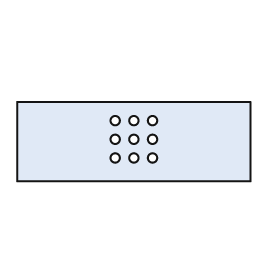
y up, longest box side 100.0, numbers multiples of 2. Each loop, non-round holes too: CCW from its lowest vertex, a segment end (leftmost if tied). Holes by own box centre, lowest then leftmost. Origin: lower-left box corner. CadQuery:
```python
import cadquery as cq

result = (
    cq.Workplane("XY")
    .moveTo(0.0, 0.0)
    .lineTo(100.0, 0.0)
    .lineTo(100.0, 34.0)
    .lineTo(0.0, 34.0)
    .close()
    .moveTo(42.0, 10.0)
    .circle(2.0)
    .moveTo(50.0, 10.0)
    .circle(2.0)
    .moveTo(58.0, 10.0)
    .circle(2.0)
    .moveTo(42.0, 18.0)
    .circle(2.0)
    .moveTo(50.0, 18.0)
    .circle(2.0)
    .moveTo(58.0, 18.0)
    .circle(2.0)
    .moveTo(42.0, 26.0)
    .circle(2.0)
    .moveTo(50.0, 26.0)
    .circle(2.0)
    .moveTo(58.0, 26.0)
    .circle(2.0)
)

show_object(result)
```